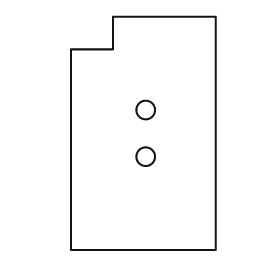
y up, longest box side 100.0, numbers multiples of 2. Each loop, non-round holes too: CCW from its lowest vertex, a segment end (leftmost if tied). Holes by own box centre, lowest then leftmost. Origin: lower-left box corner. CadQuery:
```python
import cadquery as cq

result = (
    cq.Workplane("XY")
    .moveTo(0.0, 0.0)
    .lineTo(62.0, 0.0)
    .lineTo(62.0, 100.0)
    .lineTo(18.0, 100.0)
    .lineTo(18.0, 86.0)
    .lineTo(0.0, 86.0)
    .close()
    .moveTo(32.0, 40.0)
    .circle(4.0)
    .moveTo(32.0, 60.0)
    .circle(4.0)
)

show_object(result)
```